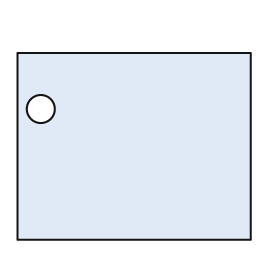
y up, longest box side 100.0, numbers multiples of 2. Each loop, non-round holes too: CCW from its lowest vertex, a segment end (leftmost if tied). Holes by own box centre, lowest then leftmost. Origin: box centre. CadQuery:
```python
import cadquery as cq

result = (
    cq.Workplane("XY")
    .moveTo(-50.0, -40.0)
    .lineTo(50.0, -40.0)
    .lineTo(50.0, 40.0)
    .lineTo(-50.0, 40.0)
    .close()
    .moveTo(-40.0, 16.0)
    .circle(6.0)
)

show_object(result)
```